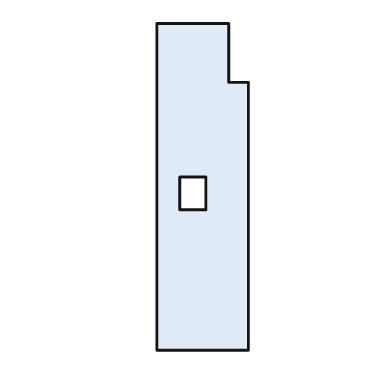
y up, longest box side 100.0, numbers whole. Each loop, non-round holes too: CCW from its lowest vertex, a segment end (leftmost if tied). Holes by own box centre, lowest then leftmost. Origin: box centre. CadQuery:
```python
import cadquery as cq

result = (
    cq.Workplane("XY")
    .moveTo(-14.0, -50.0)
    .lineTo(14.0, -50.0)
    .lineTo(14.0, 32.0)
    .lineTo(8.0, 32.0)
    .lineTo(8.0, 50.0)
    .lineTo(-14.0, 50.0)
    .close()
    .moveTo(-7.0, -7.0)
    .lineTo(1.0, -7.0)
    .lineTo(1.0, 3.0)
    .lineTo(-7.0, 3.0)
    .close()
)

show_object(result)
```